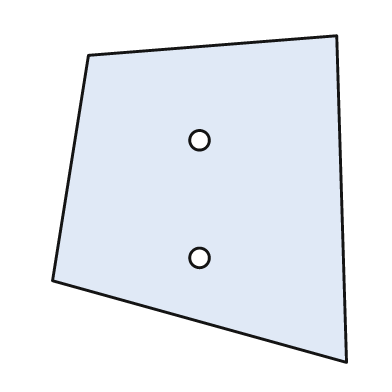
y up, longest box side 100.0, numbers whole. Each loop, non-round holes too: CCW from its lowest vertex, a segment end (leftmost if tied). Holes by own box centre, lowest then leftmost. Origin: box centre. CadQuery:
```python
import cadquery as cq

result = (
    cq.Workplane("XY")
    .moveTo(45.0, -50.0)
    .lineTo(42.0, 50.0)
    .lineTo(-34.0, 44.0)
    .lineTo(-45.0, -25.0)
    .close()
    .moveTo(0.0, -18.0)
    .circle(3.0)
    .moveTo(0.0, 18.0)
    .circle(3.0)
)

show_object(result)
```